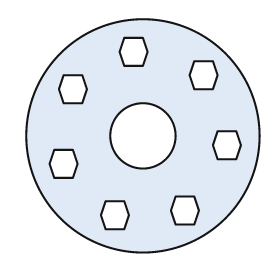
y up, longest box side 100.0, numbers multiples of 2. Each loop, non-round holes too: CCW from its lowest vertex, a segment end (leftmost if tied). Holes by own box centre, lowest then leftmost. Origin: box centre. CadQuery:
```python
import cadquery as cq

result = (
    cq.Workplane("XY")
    .moveTo(0.0, 0.0)
    .circle(50.0)
    .moveTo(-16.0, -40.0)
    .lineTo(-8.0, -40.0)
    .lineTo(-6.0, -34.0)
    .lineTo(-8.0, -28.0)
    .lineTo(-16.0, -28.0)
    .lineTo(-18.0, -34.0)
    .close()
    .moveTo(14.0, -38.0)
    .lineTo(22.0, -38.0)
    .lineTo(24.0, -32.0)
    .lineTo(22.0, -26.0)
    .lineTo(14.0, -26.0)
    .lineTo(12.0, -32.0)
    .close()
    .moveTo(-38.0, -18.0)
    .lineTo(-30.0, -18.0)
    .lineTo(-28.0, -12.0)
    .lineTo(-30.0, -6.0)
    .lineTo(-38.0, -6.0)
    .lineTo(-40.0, -12.0)
    .close()
    .moveTo(32.0, -10.0)
    .lineTo(40.0, -10.0)
    .lineTo(42.0, -4.0)
    .lineTo(40.0, 2.0)
    .lineTo(32.0, 2.0)
    .lineTo(30.0, -4.0)
    .close()
    .moveTo(0.0, 0.0)
    .circle(14.0)
    .moveTo(-34.0, 14.0)
    .lineTo(-26.0, 14.0)
    .lineTo(-24.0, 20.0)
    .lineTo(-26.0, 26.0)
    .lineTo(-34.0, 26.0)
    .lineTo(-36.0, 20.0)
    .close()
    .moveTo(22.0, 20.0)
    .lineTo(30.0, 20.0)
    .lineTo(32.0, 26.0)
    .lineTo(30.0, 32.0)
    .lineTo(22.0, 32.0)
    .lineTo(20.0, 26.0)
    .close()
    .moveTo(-8.0, 30.0)
    .lineTo(0.0, 30.0)
    .lineTo(2.0, 36.0)
    .lineTo(0.0, 42.0)
    .lineTo(-8.0, 42.0)
    .lineTo(-10.0, 36.0)
    .close()
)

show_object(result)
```